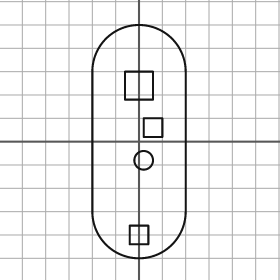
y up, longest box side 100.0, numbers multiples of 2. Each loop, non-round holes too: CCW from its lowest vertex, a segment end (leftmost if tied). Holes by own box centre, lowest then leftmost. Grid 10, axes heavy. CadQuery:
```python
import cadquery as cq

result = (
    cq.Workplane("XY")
    .moveTo(-20.0, -30.0)
    .threePointArc((0.0, -50.0), (20.0, -30.0))
    .lineTo(20.0, 30.0)
    .threePointArc((0.0, 50.0), (-20.0, 30.0))
    .close()
    .moveTo(-4.0, -44.0)
    .lineTo(4.0, -44.0)
    .lineTo(4.0, -36.0)
    .lineTo(-4.0, -36.0)
    .close()
    .moveTo(2.0, -8.0)
    .circle(4.0)
    .moveTo(2.0, 2.0)
    .lineTo(10.0, 2.0)
    .lineTo(10.0, 10.0)
    .lineTo(2.0, 10.0)
    .close()
    .moveTo(-6.0, 18.0)
    .lineTo(6.0, 18.0)
    .lineTo(6.0, 30.0)
    .lineTo(-6.0, 30.0)
    .close()
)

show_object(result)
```